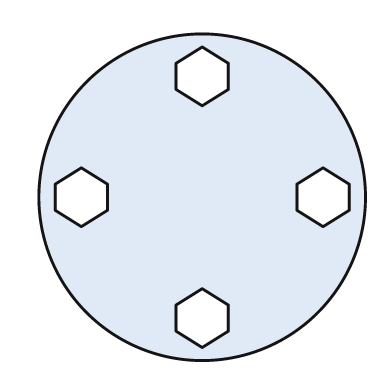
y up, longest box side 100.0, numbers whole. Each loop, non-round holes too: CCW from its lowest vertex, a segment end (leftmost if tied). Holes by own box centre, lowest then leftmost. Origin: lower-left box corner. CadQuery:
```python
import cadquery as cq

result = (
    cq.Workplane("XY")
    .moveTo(50.0, 50.0)
    .circle(50.0)
    .moveTo(50.0, 4.0)
    .lineTo(58.0, 9.0)
    .lineTo(58.0, 17.0)
    .lineTo(50.0, 22.0)
    .lineTo(42.0, 17.0)
    .lineTo(42.0, 9.0)
    .close()
    .moveTo(13.0, 41.0)
    .lineTo(21.0, 46.0)
    .lineTo(21.0, 54.0)
    .lineTo(13.0, 59.0)
    .lineTo(5.0, 54.0)
    .lineTo(5.0, 46.0)
    .close()
    .moveTo(87.0, 41.0)
    .lineTo(95.0, 46.0)
    .lineTo(95.0, 54.0)
    .lineTo(87.0, 59.0)
    .lineTo(79.0, 54.0)
    .lineTo(79.0, 46.0)
    .close()
    .moveTo(50.0, 78.0)
    .lineTo(58.0, 83.0)
    .lineTo(58.0, 91.0)
    .lineTo(50.0, 96.0)
    .lineTo(42.0, 91.0)
    .lineTo(42.0, 83.0)
    .close()
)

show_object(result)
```